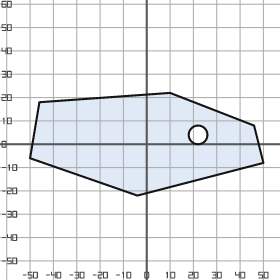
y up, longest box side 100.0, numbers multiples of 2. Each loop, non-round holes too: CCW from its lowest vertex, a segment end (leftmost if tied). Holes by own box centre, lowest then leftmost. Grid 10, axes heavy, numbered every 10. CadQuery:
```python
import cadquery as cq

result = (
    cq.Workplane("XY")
    .moveTo(-4.0, -22.0)
    .lineTo(50.0, -8.0)
    .lineTo(46.0, 8.0)
    .lineTo(10.0, 22.0)
    .lineTo(-46.0, 18.0)
    .lineTo(-50.0, -6.0)
    .close()
    .moveTo(22.0, 4.0)
    .circle(4.0)
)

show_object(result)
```